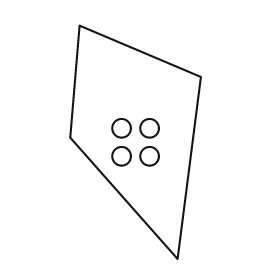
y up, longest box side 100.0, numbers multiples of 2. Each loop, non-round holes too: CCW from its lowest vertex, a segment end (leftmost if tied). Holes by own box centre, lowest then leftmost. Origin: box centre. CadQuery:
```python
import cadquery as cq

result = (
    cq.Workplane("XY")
    .moveTo(18.0, -50.0)
    .lineTo(28.0, 28.0)
    .lineTo(-24.0, 50.0)
    .lineTo(-28.0, 2.0)
    .close()
    .moveTo(-6.0, -6.0)
    .circle(4.0)
    .moveTo(6.0, -6.0)
    .circle(4.0)
    .moveTo(-6.0, 6.0)
    .circle(4.0)
    .moveTo(6.0, 6.0)
    .circle(4.0)
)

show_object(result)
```